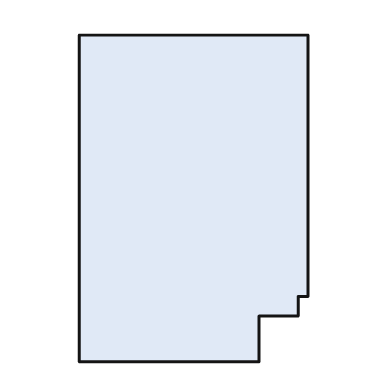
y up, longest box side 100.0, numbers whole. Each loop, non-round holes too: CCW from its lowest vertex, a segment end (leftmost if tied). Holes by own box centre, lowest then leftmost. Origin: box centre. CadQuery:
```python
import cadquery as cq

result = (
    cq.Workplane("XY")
    .moveTo(-35.0, -50.0)
    .lineTo(20.0, -50.0)
    .lineTo(20.0, -36.0)
    .lineTo(32.0, -36.0)
    .lineTo(32.0, -30.0)
    .lineTo(35.0, -30.0)
    .lineTo(35.0, 50.0)
    .lineTo(-35.0, 50.0)
    .close()
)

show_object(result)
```